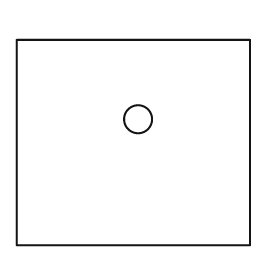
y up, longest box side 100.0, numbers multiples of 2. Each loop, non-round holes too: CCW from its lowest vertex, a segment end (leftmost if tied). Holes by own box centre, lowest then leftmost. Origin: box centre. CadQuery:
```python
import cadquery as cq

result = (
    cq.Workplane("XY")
    .moveTo(-50.0, -44.0)
    .lineTo(50.0, -44.0)
    .lineTo(50.0, 44.0)
    .lineTo(-50.0, 44.0)
    .close()
    .moveTo(2.0, 10.0)
    .circle(6.0)
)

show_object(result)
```